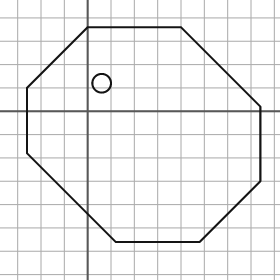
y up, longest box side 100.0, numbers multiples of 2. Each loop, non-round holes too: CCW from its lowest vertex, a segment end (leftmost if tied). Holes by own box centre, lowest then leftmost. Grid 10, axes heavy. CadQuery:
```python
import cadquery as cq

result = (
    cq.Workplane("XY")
    .moveTo(12.0, -56.0)
    .lineTo(48.0, -56.0)
    .lineTo(74.0, -30.0)
    .lineTo(74.0, 2.0)
    .lineTo(40.0, 36.0)
    .lineTo(0.0, 36.0)
    .lineTo(-26.0, 10.0)
    .lineTo(-26.0, -18.0)
    .close()
    .moveTo(6.0, 12.0)
    .circle(4.0)
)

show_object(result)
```